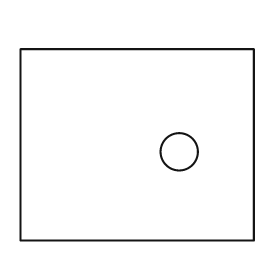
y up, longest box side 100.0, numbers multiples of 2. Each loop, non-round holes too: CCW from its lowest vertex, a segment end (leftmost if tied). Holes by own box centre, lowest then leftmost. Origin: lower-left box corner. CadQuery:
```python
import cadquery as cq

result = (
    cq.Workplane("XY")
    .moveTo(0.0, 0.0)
    .lineTo(100.0, 0.0)
    .lineTo(100.0, 82.0)
    .lineTo(0.0, 82.0)
    .close()
    .moveTo(68.0, 38.0)
    .circle(8.0)
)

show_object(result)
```